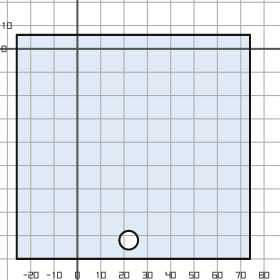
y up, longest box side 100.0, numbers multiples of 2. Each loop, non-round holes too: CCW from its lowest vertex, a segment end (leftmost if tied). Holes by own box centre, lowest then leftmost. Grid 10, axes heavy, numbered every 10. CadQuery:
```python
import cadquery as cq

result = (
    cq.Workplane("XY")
    .moveTo(-26.0, -90.0)
    .lineTo(74.0, -90.0)
    .lineTo(74.0, 6.0)
    .lineTo(-26.0, 6.0)
    .close()
    .moveTo(22.0, -82.0)
    .circle(4.0)
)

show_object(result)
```